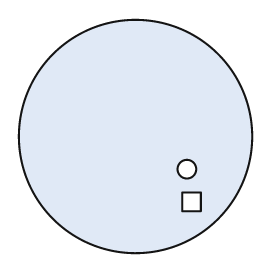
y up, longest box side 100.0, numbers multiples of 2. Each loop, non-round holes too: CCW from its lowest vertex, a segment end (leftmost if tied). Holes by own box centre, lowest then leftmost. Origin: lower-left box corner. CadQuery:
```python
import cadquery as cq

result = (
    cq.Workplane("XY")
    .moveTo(50.0, 50.0)
    .circle(50.0)
    .moveTo(70.0, 18.0)
    .lineTo(78.0, 18.0)
    .lineTo(78.0, 26.0)
    .lineTo(70.0, 26.0)
    .close()
    .moveTo(72.0, 36.0)
    .circle(4.0)
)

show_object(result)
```